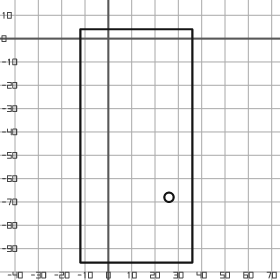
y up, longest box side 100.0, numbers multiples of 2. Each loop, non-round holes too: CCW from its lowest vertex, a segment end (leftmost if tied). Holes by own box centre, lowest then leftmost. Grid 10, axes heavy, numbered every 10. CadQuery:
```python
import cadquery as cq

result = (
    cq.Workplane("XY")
    .moveTo(-12.0, -96.0)
    .lineTo(36.0, -96.0)
    .lineTo(36.0, 4.0)
    .lineTo(-12.0, 4.0)
    .close()
    .moveTo(26.0, -68.0)
    .circle(2.0)
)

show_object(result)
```